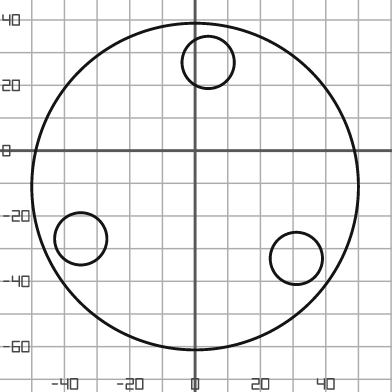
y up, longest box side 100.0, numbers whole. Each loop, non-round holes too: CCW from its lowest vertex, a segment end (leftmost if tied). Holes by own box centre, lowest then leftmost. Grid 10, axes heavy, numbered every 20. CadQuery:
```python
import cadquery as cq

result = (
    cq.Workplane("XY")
    .moveTo(0.0, -11.0)
    .circle(50.0)
    .moveTo(31.0, -33.0)
    .circle(8.0)
    .moveTo(-35.0, -27.0)
    .circle(8.0)
    .moveTo(4.0, 27.0)
    .circle(8.0)
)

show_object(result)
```